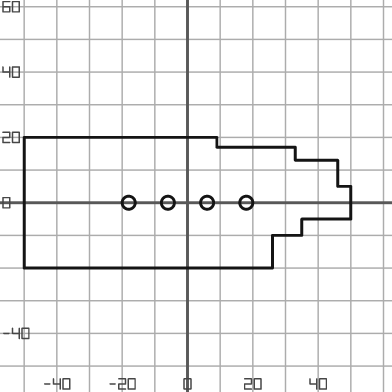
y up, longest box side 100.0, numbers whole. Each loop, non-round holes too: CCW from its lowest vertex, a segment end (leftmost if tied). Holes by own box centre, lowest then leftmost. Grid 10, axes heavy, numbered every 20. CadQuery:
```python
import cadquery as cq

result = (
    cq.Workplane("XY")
    .moveTo(-50.0, -20.0)
    .lineTo(26.0, -20.0)
    .lineTo(26.0, -10.0)
    .lineTo(35.0, -10.0)
    .lineTo(35.0, -5.0)
    .lineTo(50.0, -5.0)
    .lineTo(50.0, 5.0)
    .lineTo(46.0, 5.0)
    .lineTo(46.0, 13.0)
    .lineTo(33.0, 13.0)
    .lineTo(33.0, 17.0)
    .lineTo(9.0, 17.0)
    .lineTo(9.0, 20.0)
    .lineTo(-50.0, 20.0)
    .close()
    .moveTo(-18.0, 0.0)
    .circle(2.0)
    .moveTo(-6.0, 0.0)
    .circle(2.0)
    .moveTo(6.0, 0.0)
    .circle(2.0)
    .moveTo(18.0, 0.0)
    .circle(2.0)
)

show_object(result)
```